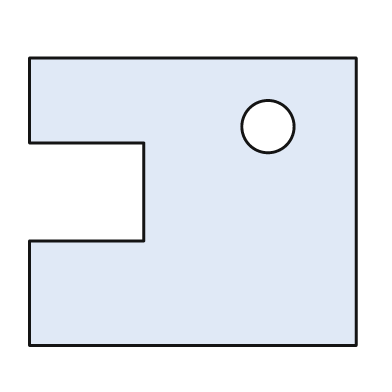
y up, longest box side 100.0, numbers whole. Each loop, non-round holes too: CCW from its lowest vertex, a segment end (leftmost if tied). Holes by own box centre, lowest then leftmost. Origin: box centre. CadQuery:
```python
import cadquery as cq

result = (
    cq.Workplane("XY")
    .moveTo(-50.0, -44.0)
    .lineTo(50.0, -44.0)
    .lineTo(50.0, 44.0)
    .lineTo(-50.0, 44.0)
    .lineTo(-50.0, 18.0)
    .lineTo(-15.0, 18.0)
    .lineTo(-15.0, -12.0)
    .lineTo(-50.0, -12.0)
    .close()
    .moveTo(23.0, 23.0)
    .circle(8.0)
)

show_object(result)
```